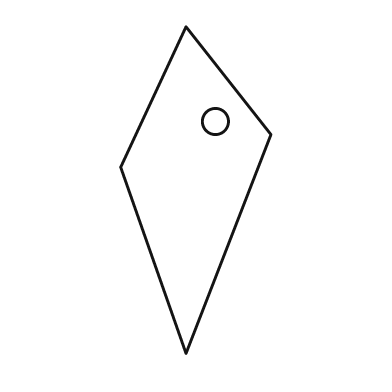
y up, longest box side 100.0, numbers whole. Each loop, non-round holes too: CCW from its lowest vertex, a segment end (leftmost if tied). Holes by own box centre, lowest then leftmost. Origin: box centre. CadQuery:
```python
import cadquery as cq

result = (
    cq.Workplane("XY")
    .moveTo(-3.0, -50.0)
    .lineTo(23.0, 17.0)
    .lineTo(-3.0, 50.0)
    .lineTo(-23.0, 7.0)
    .close()
    .moveTo(6.0, 21.0)
    .circle(4.0)
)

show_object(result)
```